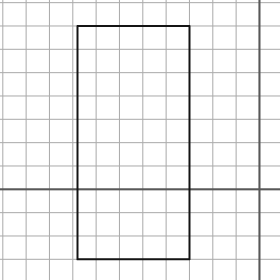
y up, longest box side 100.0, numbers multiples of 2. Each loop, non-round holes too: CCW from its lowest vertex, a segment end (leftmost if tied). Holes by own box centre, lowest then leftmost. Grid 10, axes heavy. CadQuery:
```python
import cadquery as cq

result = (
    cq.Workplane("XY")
    .moveTo(-78.0, -30.0)
    .lineTo(-30.0, -30.0)
    .lineTo(-30.0, 70.0)
    .lineTo(-78.0, 70.0)
    .close()
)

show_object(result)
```